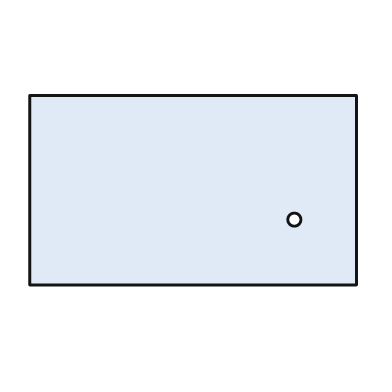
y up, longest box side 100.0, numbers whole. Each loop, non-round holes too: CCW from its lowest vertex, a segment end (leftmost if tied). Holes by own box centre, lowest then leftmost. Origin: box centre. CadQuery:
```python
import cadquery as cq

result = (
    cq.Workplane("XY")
    .moveTo(-50.0, -29.0)
    .lineTo(50.0, -29.0)
    .lineTo(50.0, 29.0)
    .lineTo(-50.0, 29.0)
    .close()
    .moveTo(31.0, -9.0)
    .circle(2.0)
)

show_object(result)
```